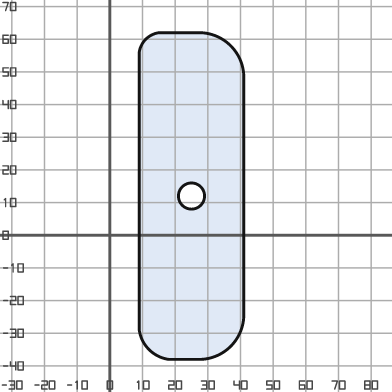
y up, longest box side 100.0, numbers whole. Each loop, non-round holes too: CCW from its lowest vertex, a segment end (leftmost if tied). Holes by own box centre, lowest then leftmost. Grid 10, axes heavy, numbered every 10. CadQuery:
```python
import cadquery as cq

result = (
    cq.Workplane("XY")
    .moveTo(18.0, -38.0)
    .lineTo(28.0, -38.0)
    .threePointArc((37.0, -34.0), (41.0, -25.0))
    .lineTo(41.0, 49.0)
    .threePointArc((37.0, 58.0), (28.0, 62.0))
    .lineTo(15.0, 62.0)
    .threePointArc((11.0, 60.0), (9.0, 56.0))
    .lineTo(9.0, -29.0)
    .threePointArc((12.0, -35.0), (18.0, -38.0))
    .close()
    .moveTo(25.0, 12.0)
    .circle(4.0)
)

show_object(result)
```